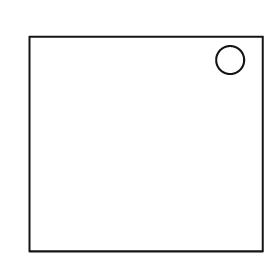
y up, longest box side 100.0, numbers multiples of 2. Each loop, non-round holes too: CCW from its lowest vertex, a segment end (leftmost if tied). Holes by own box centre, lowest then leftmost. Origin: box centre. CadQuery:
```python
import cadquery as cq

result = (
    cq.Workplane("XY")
    .moveTo(-50.0, -46.0)
    .lineTo(50.0, -46.0)
    .lineTo(50.0, 46.0)
    .lineTo(-50.0, 46.0)
    .close()
    .moveTo(36.0, 36.0)
    .circle(6.0)
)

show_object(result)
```